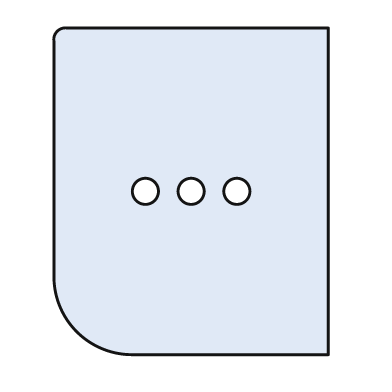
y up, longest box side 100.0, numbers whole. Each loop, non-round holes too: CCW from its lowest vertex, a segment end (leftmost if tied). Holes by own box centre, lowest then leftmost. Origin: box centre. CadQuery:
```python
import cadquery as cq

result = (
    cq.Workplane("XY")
    .moveTo(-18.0, -50.0)
    .lineTo(42.0, -50.0)
    .lineTo(42.0, 50.0)
    .lineTo(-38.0, 50.0)
    .threePointArc((-41.0, 49.0), (-42.0, 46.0))
    .lineTo(-42.0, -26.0)
    .threePointArc((-35.0, -43.0), (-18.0, -50.0))
    .close()
    .moveTo(-14.0, 0.0)
    .circle(4.0)
    .moveTo(0.0, 0.0)
    .circle(4.0)
    .moveTo(14.0, 0.0)
    .circle(4.0)
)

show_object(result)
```